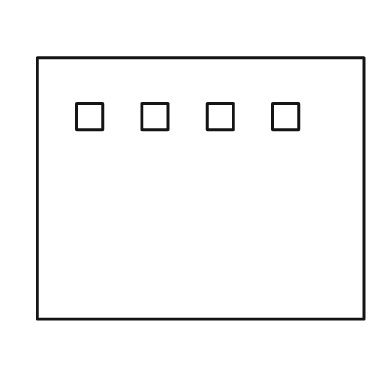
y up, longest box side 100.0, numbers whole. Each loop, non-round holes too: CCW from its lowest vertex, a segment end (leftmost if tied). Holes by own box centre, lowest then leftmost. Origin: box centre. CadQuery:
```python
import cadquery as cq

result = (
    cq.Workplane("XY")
    .moveTo(-50.0, -40.0)
    .lineTo(50.0, -40.0)
    .lineTo(50.0, 40.0)
    .lineTo(-50.0, 40.0)
    .close()
    .moveTo(-38.0, 18.0)
    .lineTo(-30.0, 18.0)
    .lineTo(-30.0, 26.0)
    .lineTo(-38.0, 26.0)
    .close()
    .moveTo(-18.0, 18.0)
    .lineTo(-10.0, 18.0)
    .lineTo(-10.0, 26.0)
    .lineTo(-18.0, 26.0)
    .close()
    .moveTo(2.0, 18.0)
    .lineTo(10.0, 18.0)
    .lineTo(10.0, 26.0)
    .lineTo(2.0, 26.0)
    .close()
    .moveTo(22.0, 18.0)
    .lineTo(30.0, 18.0)
    .lineTo(30.0, 26.0)
    .lineTo(22.0, 26.0)
    .close()
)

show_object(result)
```